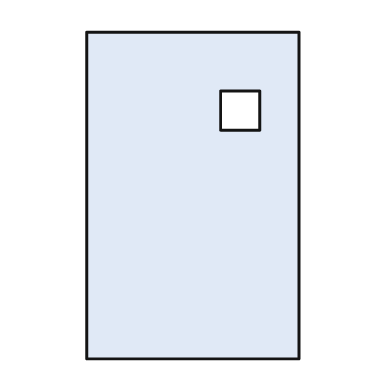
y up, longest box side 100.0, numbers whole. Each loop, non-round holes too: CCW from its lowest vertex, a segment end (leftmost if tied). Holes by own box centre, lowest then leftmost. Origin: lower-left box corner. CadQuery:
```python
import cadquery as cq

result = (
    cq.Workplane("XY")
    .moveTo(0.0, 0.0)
    .lineTo(65.0, 0.0)
    .lineTo(65.0, 100.0)
    .lineTo(0.0, 100.0)
    .close()
    .moveTo(41.0, 70.0)
    .lineTo(53.0, 70.0)
    .lineTo(53.0, 82.0)
    .lineTo(41.0, 82.0)
    .close()
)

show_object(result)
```